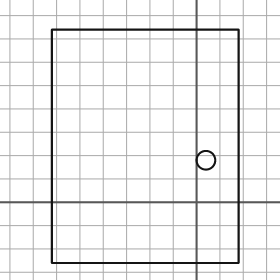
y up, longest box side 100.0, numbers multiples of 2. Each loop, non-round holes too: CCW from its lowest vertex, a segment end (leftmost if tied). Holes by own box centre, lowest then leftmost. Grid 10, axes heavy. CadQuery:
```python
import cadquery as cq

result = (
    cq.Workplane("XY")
    .moveTo(-62.0, -26.0)
    .lineTo(18.0, -26.0)
    .lineTo(18.0, 74.0)
    .lineTo(-62.0, 74.0)
    .close()
    .moveTo(4.0, 18.0)
    .circle(4.0)
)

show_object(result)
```